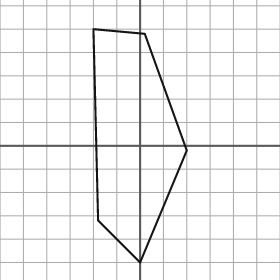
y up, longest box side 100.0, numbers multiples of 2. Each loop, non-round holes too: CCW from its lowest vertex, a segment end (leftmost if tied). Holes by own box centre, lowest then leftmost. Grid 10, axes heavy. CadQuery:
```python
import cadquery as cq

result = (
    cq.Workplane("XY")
    .moveTo(0.0, -50.0)
    .lineTo(20.0, -2.0)
    .lineTo(2.0, 48.0)
    .lineTo(-20.0, 50.0)
    .lineTo(-18.0, -32.0)
    .close()
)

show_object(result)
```